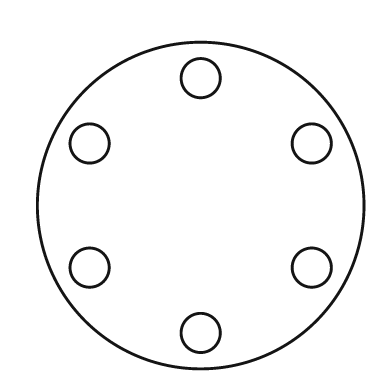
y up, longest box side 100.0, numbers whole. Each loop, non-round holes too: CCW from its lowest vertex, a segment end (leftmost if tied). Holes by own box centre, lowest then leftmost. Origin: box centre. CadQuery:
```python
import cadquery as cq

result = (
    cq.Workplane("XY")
    .moveTo(0.0, 0.0)
    .circle(50.0)
    .moveTo(0.0, -39.0)
    .circle(6.0)
    .moveTo(-34.0, -19.0)
    .circle(6.0)
    .moveTo(34.0, -19.0)
    .circle(6.0)
    .moveTo(-34.0, 19.0)
    .circle(6.0)
    .moveTo(34.0, 19.0)
    .circle(6.0)
    .moveTo(0.0, 39.0)
    .circle(6.0)
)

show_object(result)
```